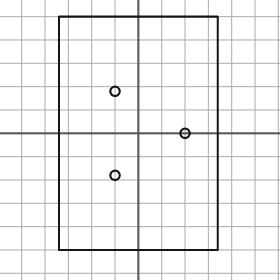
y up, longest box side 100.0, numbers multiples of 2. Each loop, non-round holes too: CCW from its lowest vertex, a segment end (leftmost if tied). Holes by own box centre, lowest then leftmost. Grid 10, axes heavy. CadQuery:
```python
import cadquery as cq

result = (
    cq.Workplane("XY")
    .moveTo(-34.0, -50.0)
    .lineTo(34.0, -50.0)
    .lineTo(34.0, 50.0)
    .lineTo(-34.0, 50.0)
    .close()
    .moveTo(-10.0, -18.0)
    .circle(2.0)
    .moveTo(20.0, 0.0)
    .circle(2.0)
    .moveTo(-10.0, 18.0)
    .circle(2.0)
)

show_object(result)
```